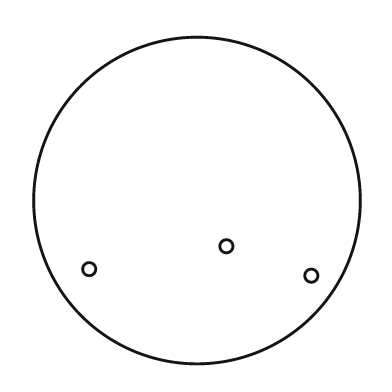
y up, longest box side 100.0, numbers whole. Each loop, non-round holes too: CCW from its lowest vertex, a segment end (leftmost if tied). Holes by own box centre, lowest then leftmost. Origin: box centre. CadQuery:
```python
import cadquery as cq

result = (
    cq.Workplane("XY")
    .moveTo(0.0, 0.0)
    .circle(50.0)
    .moveTo(35.0, -23.0)
    .circle(2.0)
    .moveTo(-33.0, -21.0)
    .circle(2.0)
    .moveTo(9.0, -14.0)
    .circle(2.0)
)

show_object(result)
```